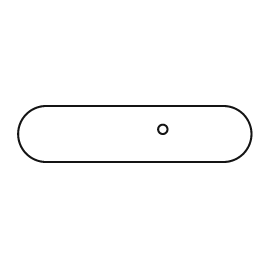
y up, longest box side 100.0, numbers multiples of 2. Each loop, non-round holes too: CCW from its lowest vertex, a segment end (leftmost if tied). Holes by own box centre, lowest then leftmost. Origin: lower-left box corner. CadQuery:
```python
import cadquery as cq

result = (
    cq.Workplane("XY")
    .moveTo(12.0, 0.0)
    .lineTo(88.0, 0.0)
    .threePointArc((100.0, 12.0), (88.0, 24.0))
    .lineTo(12.0, 24.0)
    .threePointArc((0.0, 12.0), (12.0, 0.0))
    .close()
    .moveTo(62.0, 14.0)
    .circle(2.0)
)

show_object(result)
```